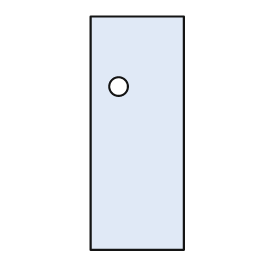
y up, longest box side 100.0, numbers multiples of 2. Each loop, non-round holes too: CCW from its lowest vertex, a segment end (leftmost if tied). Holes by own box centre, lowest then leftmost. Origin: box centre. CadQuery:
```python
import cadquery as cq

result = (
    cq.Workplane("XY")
    .moveTo(-20.0, -50.0)
    .lineTo(20.0, -50.0)
    .lineTo(20.0, 50.0)
    .lineTo(-20.0, 50.0)
    .close()
    .moveTo(-8.0, 20.0)
    .circle(4.0)
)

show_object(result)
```